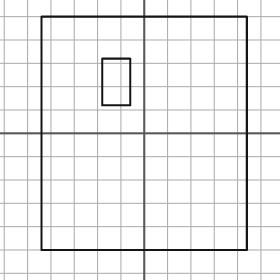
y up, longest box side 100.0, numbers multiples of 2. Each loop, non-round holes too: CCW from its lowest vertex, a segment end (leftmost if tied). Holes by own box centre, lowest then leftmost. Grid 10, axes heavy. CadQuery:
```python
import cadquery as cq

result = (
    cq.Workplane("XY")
    .moveTo(-44.0, -50.0)
    .lineTo(44.0, -50.0)
    .lineTo(44.0, 50.0)
    .lineTo(-44.0, 50.0)
    .close()
    .moveTo(-18.0, 12.0)
    .lineTo(-6.0, 12.0)
    .lineTo(-6.0, 32.0)
    .lineTo(-18.0, 32.0)
    .close()
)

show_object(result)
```